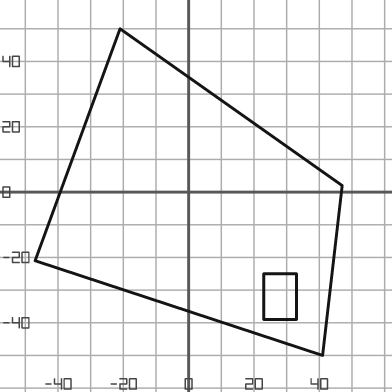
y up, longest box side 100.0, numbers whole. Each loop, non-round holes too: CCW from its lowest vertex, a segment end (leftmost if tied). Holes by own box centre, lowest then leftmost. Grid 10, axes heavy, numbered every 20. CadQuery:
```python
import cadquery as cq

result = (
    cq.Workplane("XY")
    .moveTo(41.0, -50.0)
    .lineTo(47.0, 2.0)
    .lineTo(-21.0, 50.0)
    .lineTo(-47.0, -21.0)
    .close()
    .moveTo(23.0, -39.0)
    .lineTo(33.0, -39.0)
    .lineTo(33.0, -25.0)
    .lineTo(23.0, -25.0)
    .close()
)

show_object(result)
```